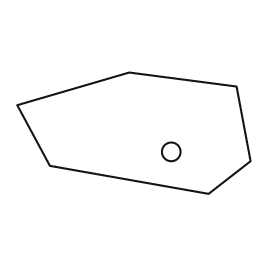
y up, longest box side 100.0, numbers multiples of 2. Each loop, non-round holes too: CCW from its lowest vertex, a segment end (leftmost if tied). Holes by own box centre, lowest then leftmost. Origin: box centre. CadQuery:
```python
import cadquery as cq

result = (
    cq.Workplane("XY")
    .moveTo(32.0, -26.0)
    .lineTo(50.0, -12.0)
    .lineTo(44.0, 20.0)
    .lineTo(-2.0, 26.0)
    .lineTo(-50.0, 12.0)
    .lineTo(-36.0, -14.0)
    .close()
    .moveTo(16.0, -8.0)
    .circle(4.0)
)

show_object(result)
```